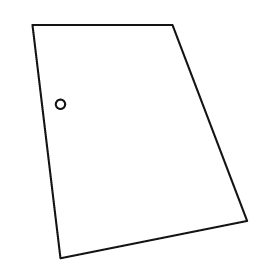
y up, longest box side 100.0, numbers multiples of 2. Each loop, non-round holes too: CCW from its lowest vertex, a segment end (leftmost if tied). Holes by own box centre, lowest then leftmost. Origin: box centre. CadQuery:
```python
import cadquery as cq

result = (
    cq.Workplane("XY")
    .moveTo(-34.0, -50.0)
    .lineTo(46.0, -34.0)
    .lineTo(14.0, 50.0)
    .lineTo(-46.0, 50.0)
    .close()
    .moveTo(-34.0, 16.0)
    .circle(2.0)
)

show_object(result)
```